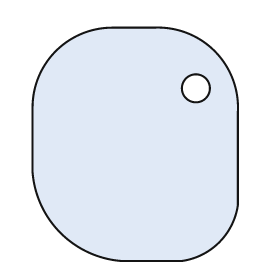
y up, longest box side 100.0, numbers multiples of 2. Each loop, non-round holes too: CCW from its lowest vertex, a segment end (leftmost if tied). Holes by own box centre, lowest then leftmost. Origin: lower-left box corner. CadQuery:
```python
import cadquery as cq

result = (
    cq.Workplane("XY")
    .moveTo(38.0, 0.0)
    .lineTo(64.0, 0.0)
    .threePointArc((80.0, 8.0), (88.0, 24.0))
    .lineTo(88.0, 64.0)
    .threePointArc((78.0, 90.0), (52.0, 100.0))
    .lineTo(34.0, 100.0)
    .threePointArc((10.0, 90.0), (0.0, 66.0))
    .lineTo(0.0, 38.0)
    .threePointArc((12.0, 12.0), (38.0, 0.0))
    .close()
    .moveTo(70.0, 74.0)
    .circle(6.0)
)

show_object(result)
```